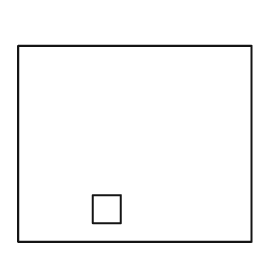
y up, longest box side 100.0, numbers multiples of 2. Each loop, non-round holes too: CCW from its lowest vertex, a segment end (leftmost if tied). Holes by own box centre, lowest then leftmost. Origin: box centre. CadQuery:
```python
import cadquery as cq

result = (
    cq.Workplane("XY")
    .moveTo(-50.0, -42.0)
    .lineTo(50.0, -42.0)
    .lineTo(50.0, 42.0)
    .lineTo(-50.0, 42.0)
    .close()
    .moveTo(-18.0, -34.0)
    .lineTo(-6.0, -34.0)
    .lineTo(-6.0, -22.0)
    .lineTo(-18.0, -22.0)
    .close()
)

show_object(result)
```